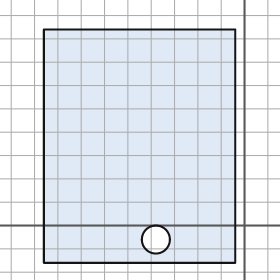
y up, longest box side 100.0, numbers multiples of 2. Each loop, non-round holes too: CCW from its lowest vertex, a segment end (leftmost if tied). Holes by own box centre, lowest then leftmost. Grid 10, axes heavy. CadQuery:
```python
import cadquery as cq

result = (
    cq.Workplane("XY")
    .moveTo(-86.0, -16.0)
    .lineTo(-4.0, -16.0)
    .lineTo(-4.0, 84.0)
    .lineTo(-86.0, 84.0)
    .close()
    .moveTo(-38.0, -6.0)
    .circle(6.0)
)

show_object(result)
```